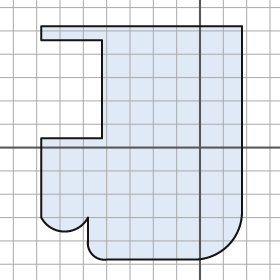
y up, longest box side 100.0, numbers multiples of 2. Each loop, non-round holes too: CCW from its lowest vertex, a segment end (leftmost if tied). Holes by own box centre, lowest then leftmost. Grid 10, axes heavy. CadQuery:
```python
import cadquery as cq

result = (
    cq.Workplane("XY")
    .moveTo(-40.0, -48.0)
    .lineTo(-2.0, -48.0)
    .threePointArc((12.0, -42.0), (18.0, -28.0))
    .lineTo(18.0, 52.0)
    .lineTo(-68.0, 52.0)
    .lineTo(-68.0, 46.0)
    .lineTo(-42.0, 46.0)
    .lineTo(-42.0, 4.0)
    .lineTo(-68.0, 4.0)
    .lineTo(-68.0, -30.0)
    .threePointArc((-58.0, -36.0), (-48.0, -30.0))
    .lineTo(-48.0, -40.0)
    .threePointArc((-46.0, -46.0), (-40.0, -48.0))
    .close()
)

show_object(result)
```